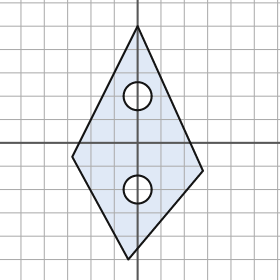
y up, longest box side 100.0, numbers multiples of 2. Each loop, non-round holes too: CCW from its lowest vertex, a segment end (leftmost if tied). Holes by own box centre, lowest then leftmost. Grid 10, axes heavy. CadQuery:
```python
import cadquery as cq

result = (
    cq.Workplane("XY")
    .moveTo(-4.0, -50.0)
    .lineTo(28.0, -12.0)
    .lineTo(0.0, 50.0)
    .lineTo(-28.0, -6.0)
    .close()
    .moveTo(0.0, -20.0)
    .circle(6.0)
    .moveTo(0.0, 20.0)
    .circle(6.0)
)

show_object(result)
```